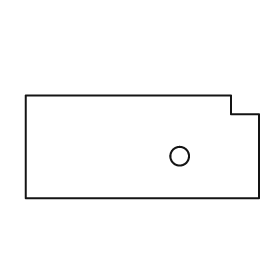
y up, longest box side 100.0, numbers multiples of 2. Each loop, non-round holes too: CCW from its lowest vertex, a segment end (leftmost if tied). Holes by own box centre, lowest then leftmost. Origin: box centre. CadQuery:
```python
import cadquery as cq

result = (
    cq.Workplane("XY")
    .moveTo(-50.0, -22.0)
    .lineTo(50.0, -22.0)
    .lineTo(50.0, 14.0)
    .lineTo(38.0, 14.0)
    .lineTo(38.0, 22.0)
    .lineTo(-50.0, 22.0)
    .close()
    .moveTo(16.0, -4.0)
    .circle(4.0)
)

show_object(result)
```